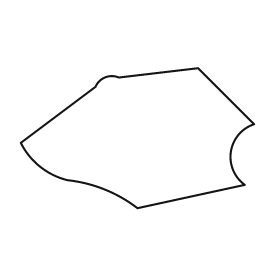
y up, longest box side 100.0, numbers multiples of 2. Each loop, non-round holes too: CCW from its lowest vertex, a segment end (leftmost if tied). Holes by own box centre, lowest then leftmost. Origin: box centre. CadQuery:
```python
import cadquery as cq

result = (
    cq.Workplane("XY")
    .moveTo(0.0, -30.0)
    .lineTo(46.0, -20.0)
    .threePointArc((40.0, -6.0), (50.0, 6.0))
    .lineTo(26.0, 30.0)
    .lineTo(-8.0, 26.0)
    .threePointArc((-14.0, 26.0), (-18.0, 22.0))
    .lineTo(-50.0, -2.0)
    .threePointArc((-42.0, -12.0), (-30.0, -18.0))
    .threePointArc((-14.0, -22.0), (0.0, -30.0))
    .close()
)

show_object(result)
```